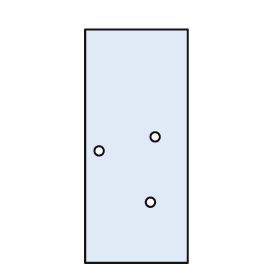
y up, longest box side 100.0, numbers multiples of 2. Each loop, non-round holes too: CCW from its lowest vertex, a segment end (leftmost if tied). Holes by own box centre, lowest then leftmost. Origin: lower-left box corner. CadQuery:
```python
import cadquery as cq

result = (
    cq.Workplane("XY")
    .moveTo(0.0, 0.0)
    .lineTo(44.0, 0.0)
    .lineTo(44.0, 100.0)
    .lineTo(0.0, 100.0)
    .close()
    .moveTo(28.0, 26.0)
    .circle(2.0)
    .moveTo(6.0, 48.0)
    .circle(2.0)
    .moveTo(30.0, 54.0)
    .circle(2.0)
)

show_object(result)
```